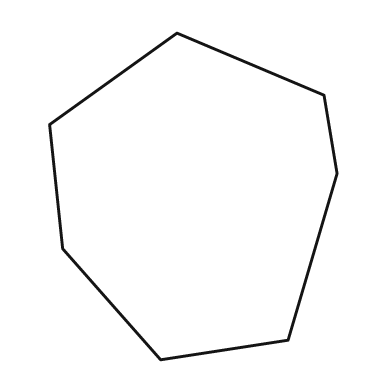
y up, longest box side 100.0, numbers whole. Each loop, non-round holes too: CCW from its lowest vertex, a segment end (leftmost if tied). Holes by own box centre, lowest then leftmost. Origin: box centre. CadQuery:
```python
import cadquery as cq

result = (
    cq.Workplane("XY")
    .moveTo(-10.0, -50.0)
    .lineTo(29.0, -44.0)
    .lineTo(44.0, 7.0)
    .lineTo(40.0, 31.0)
    .lineTo(-5.0, 50.0)
    .lineTo(-44.0, 22.0)
    .lineTo(-40.0, -16.0)
    .close()
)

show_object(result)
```